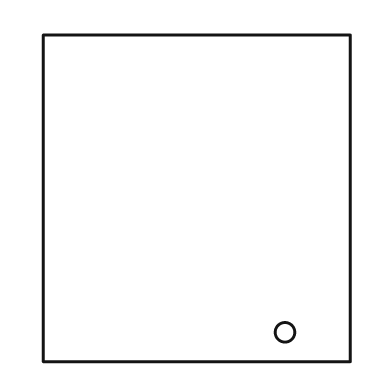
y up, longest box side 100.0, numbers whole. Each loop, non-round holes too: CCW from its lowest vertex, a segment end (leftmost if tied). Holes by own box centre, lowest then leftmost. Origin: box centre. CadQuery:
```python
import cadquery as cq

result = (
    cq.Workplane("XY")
    .moveTo(-47.0, -50.0)
    .lineTo(47.0, -50.0)
    .lineTo(47.0, 50.0)
    .lineTo(-47.0, 50.0)
    .close()
    .moveTo(27.0, -41.0)
    .circle(3.0)
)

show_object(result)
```